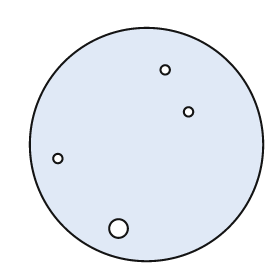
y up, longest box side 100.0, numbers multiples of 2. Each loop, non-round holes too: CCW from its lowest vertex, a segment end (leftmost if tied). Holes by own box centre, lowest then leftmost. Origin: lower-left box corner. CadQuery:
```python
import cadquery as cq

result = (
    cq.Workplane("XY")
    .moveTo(50.0, 50.0)
    .circle(50.0)
    .moveTo(38.0, 14.0)
    .circle(4.0)
    .moveTo(12.0, 44.0)
    .circle(2.0)
    .moveTo(68.0, 64.0)
    .circle(2.0)
    .moveTo(58.0, 82.0)
    .circle(2.0)
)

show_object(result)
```